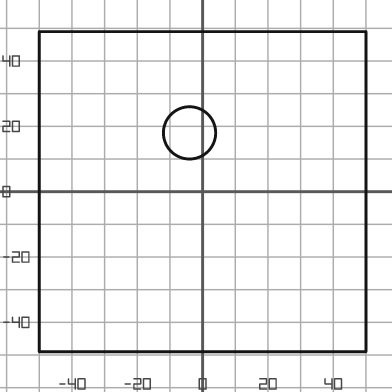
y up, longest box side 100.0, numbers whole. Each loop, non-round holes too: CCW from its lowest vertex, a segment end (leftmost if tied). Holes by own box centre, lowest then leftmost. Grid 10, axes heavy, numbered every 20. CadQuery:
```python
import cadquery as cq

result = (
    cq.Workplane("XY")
    .moveTo(-50.0, -49.0)
    .lineTo(50.0, -49.0)
    .lineTo(50.0, 49.0)
    .lineTo(-50.0, 49.0)
    .close()
    .moveTo(-4.0, 18.0)
    .circle(8.0)
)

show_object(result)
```